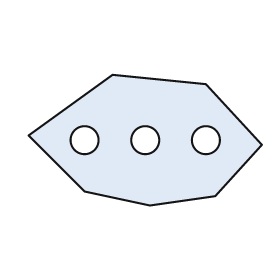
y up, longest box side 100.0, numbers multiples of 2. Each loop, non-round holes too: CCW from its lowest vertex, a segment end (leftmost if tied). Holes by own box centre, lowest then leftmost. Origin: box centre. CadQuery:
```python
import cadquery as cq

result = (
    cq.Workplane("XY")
    .moveTo(2.0, -28.0)
    .lineTo(30.0, -24.0)
    .lineTo(50.0, -2.0)
    .lineTo(26.0, 24.0)
    .lineTo(-14.0, 28.0)
    .lineTo(-50.0, 2.0)
    .lineTo(-26.0, -22.0)
    .close()
    .moveTo(-26.0, 0.0)
    .circle(6.0)
    .moveTo(0.0, 0.0)
    .circle(6.0)
    .moveTo(26.0, 0.0)
    .circle(6.0)
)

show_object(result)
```